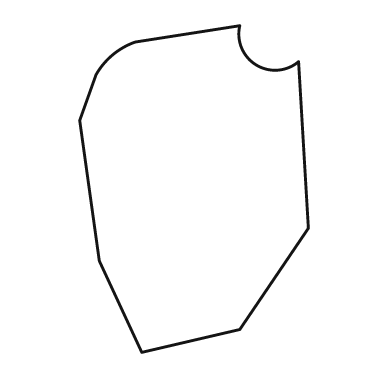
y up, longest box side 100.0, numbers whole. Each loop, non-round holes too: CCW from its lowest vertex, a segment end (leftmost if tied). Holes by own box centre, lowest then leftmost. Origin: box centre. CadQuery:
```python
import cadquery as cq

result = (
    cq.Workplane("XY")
    .moveTo(-16.0, -50.0)
    .lineTo(14.0, -43.0)
    .lineTo(35.0, -12.0)
    .lineTo(32.0, 39.0)
    .threePointArc((19.0, 38.0), (14.0, 50.0))
    .lineTo(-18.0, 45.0)
    .threePointArc((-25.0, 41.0), (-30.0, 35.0))
    .lineTo(-35.0, 21.0)
    .lineTo(-29.0, -22.0)
    .close()
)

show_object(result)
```